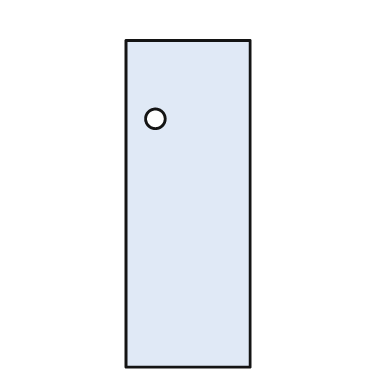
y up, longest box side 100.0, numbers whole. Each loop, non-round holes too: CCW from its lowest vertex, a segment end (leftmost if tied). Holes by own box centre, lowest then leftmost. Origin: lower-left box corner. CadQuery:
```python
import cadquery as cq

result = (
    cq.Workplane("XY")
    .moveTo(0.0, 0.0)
    .lineTo(38.0, 0.0)
    .lineTo(38.0, 100.0)
    .lineTo(0.0, 100.0)
    .close()
    .moveTo(9.0, 76.0)
    .circle(3.0)
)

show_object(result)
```